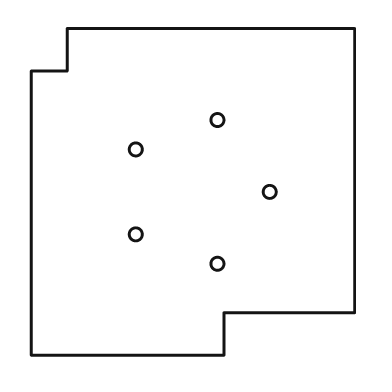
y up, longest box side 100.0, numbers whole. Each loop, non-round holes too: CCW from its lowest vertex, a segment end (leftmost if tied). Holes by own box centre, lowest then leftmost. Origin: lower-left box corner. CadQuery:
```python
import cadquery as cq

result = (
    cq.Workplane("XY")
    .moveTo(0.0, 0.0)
    .lineTo(59.0, 0.0)
    .lineTo(59.0, 13.0)
    .lineTo(99.0, 13.0)
    .lineTo(99.0, 100.0)
    .lineTo(11.0, 100.0)
    .lineTo(11.0, 87.0)
    .lineTo(0.0, 87.0)
    .close()
    .moveTo(57.0, 28.0)
    .circle(2.0)
    .moveTo(32.0, 37.0)
    .circle(2.0)
    .moveTo(73.0, 50.0)
    .circle(2.0)
    .moveTo(32.0, 63.0)
    .circle(2.0)
    .moveTo(57.0, 72.0)
    .circle(2.0)
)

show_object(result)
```